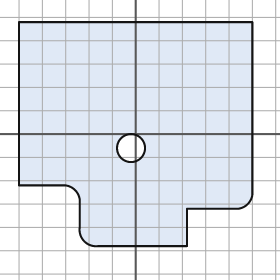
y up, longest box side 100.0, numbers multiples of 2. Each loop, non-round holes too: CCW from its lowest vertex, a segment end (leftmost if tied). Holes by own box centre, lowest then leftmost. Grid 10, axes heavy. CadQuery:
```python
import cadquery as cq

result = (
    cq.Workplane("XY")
    .moveTo(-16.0, -48.0)
    .lineTo(22.0, -48.0)
    .lineTo(22.0, -32.0)
    .lineTo(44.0, -32.0)
    .threePointArc((48.0, -30.0), (50.0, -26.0))
    .lineTo(50.0, 48.0)
    .lineTo(-50.0, 48.0)
    .lineTo(-50.0, -22.0)
    .lineTo(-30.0, -22.0)
    .threePointArc((-26.0, -24.0), (-24.0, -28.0))
    .lineTo(-24.0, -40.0)
    .threePointArc((-22.0, -46.0), (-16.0, -48.0))
    .close()
    .moveTo(-2.0, -6.0)
    .circle(6.0)
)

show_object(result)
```